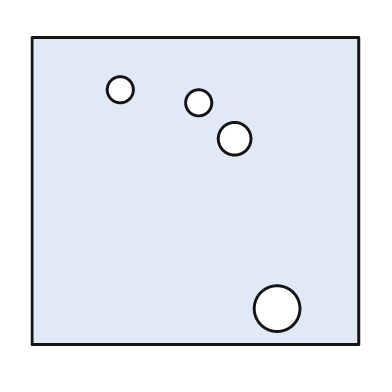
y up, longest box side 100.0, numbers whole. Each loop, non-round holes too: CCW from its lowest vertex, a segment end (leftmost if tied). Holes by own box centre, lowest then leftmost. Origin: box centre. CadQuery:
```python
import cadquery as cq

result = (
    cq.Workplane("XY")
    .moveTo(-50.0, -47.0)
    .lineTo(50.0, -47.0)
    .lineTo(50.0, 47.0)
    .lineTo(-50.0, 47.0)
    .close()
    .moveTo(25.0, -36.0)
    .circle(7.0)
    .moveTo(12.0, 16.0)
    .circle(5.0)
    .moveTo(1.0, 27.0)
    .circle(4.0)
    .moveTo(-23.0, 31.0)
    .circle(4.0)
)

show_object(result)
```